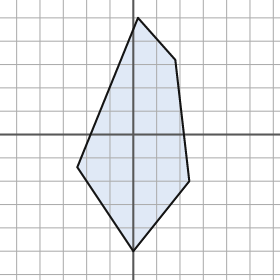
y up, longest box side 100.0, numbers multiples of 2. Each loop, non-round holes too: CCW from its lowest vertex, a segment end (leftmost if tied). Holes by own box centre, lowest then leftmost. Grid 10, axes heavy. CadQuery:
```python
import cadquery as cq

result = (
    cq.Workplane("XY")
    .moveTo(0.0, -50.0)
    .lineTo(24.0, -20.0)
    .lineTo(18.0, 32.0)
    .lineTo(2.0, 50.0)
    .lineTo(-24.0, -14.0)
    .close()
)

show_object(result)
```